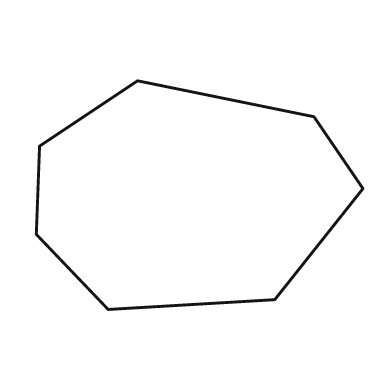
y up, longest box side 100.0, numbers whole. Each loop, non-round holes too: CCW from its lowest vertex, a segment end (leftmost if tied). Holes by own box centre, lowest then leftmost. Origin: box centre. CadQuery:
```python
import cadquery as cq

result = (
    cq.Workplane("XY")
    .moveTo(-28.0, -35.0)
    .lineTo(23.0, -32.0)
    .lineTo(50.0, 2.0)
    .lineTo(35.0, 24.0)
    .lineTo(-19.0, 35.0)
    .lineTo(-49.0, 15.0)
    .lineTo(-50.0, -12.0)
    .close()
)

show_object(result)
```